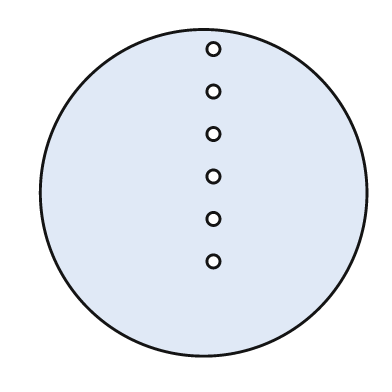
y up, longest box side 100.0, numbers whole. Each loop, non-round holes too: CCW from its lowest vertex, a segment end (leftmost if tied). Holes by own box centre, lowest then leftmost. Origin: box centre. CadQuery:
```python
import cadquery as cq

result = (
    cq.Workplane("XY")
    .moveTo(0.0, 0.0)
    .circle(50.0)
    .moveTo(3.0, -21.0)
    .circle(2.0)
    .moveTo(3.0, -8.0)
    .circle(2.0)
    .moveTo(3.0, 5.0)
    .circle(2.0)
    .moveTo(3.0, 18.0)
    .circle(2.0)
    .moveTo(3.0, 31.0)
    .circle(2.0)
    .moveTo(3.0, 44.0)
    .circle(2.0)
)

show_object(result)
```